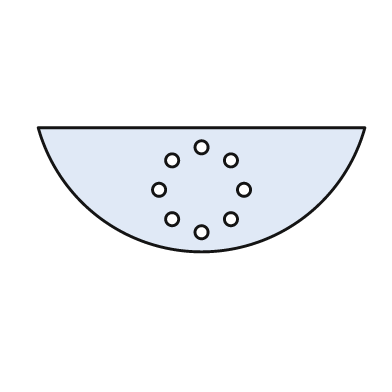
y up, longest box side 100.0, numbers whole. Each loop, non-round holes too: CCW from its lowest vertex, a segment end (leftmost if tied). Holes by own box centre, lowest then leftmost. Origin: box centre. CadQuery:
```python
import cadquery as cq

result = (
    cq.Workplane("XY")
    .moveTo(-50.0, 19.0)
    .threePointArc((0.0, -19.0), (50.0, 19.0))
    .close()
    .moveTo(0.0, -13.0)
    .circle(2.0)
    .moveTo(-9.0, -9.0)
    .circle(2.0)
    .moveTo(9.0, -9.0)
    .circle(2.0)
    .moveTo(-13.0, 0.0)
    .circle(2.0)
    .moveTo(13.0, 0.0)
    .circle(2.0)
    .moveTo(-9.0, 9.0)
    .circle(2.0)
    .moveTo(9.0, 9.0)
    .circle(2.0)
    .moveTo(0.0, 13.0)
    .circle(2.0)
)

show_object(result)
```